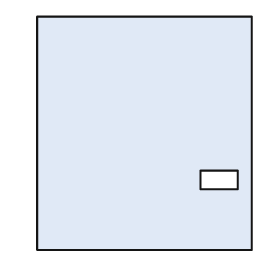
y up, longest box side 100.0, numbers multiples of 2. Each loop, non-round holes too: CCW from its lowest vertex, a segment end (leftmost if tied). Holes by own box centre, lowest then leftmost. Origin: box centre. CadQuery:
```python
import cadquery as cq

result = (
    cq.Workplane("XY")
    .moveTo(-46.0, -50.0)
    .lineTo(46.0, -50.0)
    .lineTo(46.0, 50.0)
    .lineTo(-46.0, 50.0)
    .close()
    .moveTo(24.0, -24.0)
    .lineTo(40.0, -24.0)
    .lineTo(40.0, -16.0)
    .lineTo(24.0, -16.0)
    .close()
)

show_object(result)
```